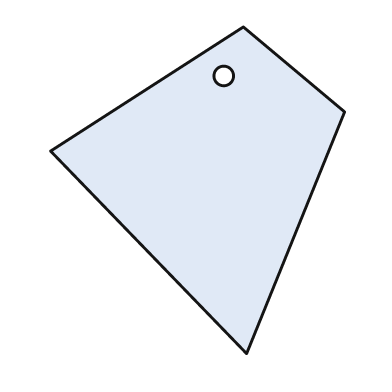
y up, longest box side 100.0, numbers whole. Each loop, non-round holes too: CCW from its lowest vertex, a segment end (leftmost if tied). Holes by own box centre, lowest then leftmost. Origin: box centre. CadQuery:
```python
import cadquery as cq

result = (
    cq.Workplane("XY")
    .moveTo(15.0, -50.0)
    .lineTo(45.0, 24.0)
    .lineTo(14.0, 50.0)
    .lineTo(-45.0, 12.0)
    .close()
    .moveTo(8.0, 35.0)
    .circle(3.0)
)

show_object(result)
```